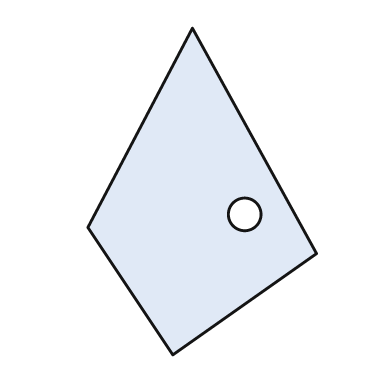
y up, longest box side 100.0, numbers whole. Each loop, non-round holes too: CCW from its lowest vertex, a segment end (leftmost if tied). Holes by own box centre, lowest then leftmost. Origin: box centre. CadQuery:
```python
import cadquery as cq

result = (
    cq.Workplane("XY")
    .moveTo(-9.0, -50.0)
    .lineTo(35.0, -19.0)
    .lineTo(-3.0, 50.0)
    .lineTo(-35.0, -11.0)
    .close()
    .moveTo(13.0, -7.0)
    .circle(5.0)
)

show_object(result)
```